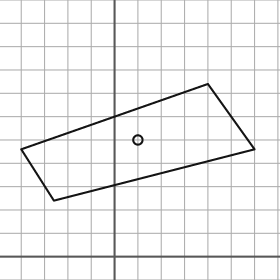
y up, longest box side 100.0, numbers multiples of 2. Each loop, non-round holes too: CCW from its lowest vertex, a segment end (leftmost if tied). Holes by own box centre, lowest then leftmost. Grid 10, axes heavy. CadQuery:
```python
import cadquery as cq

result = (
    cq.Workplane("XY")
    .moveTo(-26.0, 24.0)
    .lineTo(60.0, 46.0)
    .lineTo(40.0, 74.0)
    .lineTo(-40.0, 46.0)
    .close()
    .moveTo(10.0, 50.0)
    .circle(2.0)
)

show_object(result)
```